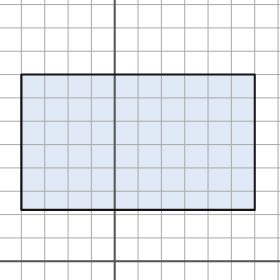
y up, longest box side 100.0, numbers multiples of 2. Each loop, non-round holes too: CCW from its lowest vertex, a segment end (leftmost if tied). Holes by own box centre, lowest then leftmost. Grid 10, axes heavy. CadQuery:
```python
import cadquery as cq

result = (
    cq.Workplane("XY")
    .moveTo(-40.0, 22.0)
    .lineTo(60.0, 22.0)
    .lineTo(60.0, 80.0)
    .lineTo(-40.0, 80.0)
    .close()
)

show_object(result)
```